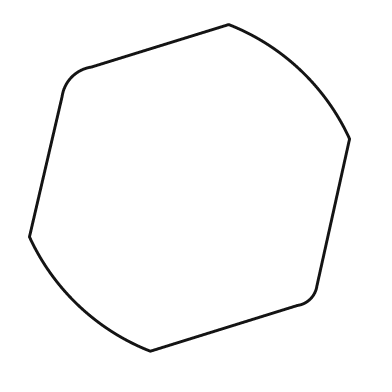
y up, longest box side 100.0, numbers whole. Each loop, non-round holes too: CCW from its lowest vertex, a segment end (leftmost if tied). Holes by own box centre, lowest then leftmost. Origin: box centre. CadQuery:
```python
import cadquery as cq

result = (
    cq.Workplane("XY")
    .moveTo(-12.0, -50.0)
    .lineTo(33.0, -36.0)
    .threePointArc((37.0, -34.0), (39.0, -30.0))
    .lineTo(49.0, 15.0)
    .threePointArc((34.0, 36.0), (12.0, 50.0))
    .lineTo(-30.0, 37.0)
    .threePointArc((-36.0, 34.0), (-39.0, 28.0))
    .lineTo(-49.0, -15.0)
    .threePointArc((-34.0, -36.0), (-12.0, -50.0))
    .close()
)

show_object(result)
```